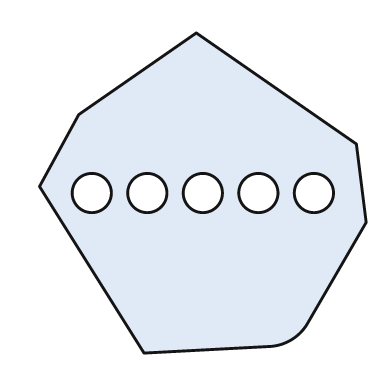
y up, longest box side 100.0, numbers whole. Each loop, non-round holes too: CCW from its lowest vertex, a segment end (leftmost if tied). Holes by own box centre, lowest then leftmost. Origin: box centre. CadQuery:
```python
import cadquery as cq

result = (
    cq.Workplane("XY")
    .moveTo(-18.0, -49.0)
    .lineTo(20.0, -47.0)
    .threePointArc((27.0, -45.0), (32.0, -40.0))
    .lineTo(50.0, -9.0)
    .lineTo(47.0, 15.0)
    .lineTo(-2.0, 49.0)
    .lineTo(-38.0, 24.0)
    .lineTo(-50.0, 2.0)
    .close()
    .moveTo(-34.0, 0.0)
    .circle(6.0)
    .moveTo(-17.0, 0.0)
    .circle(6.0)
    .moveTo(0.0, 0.0)
    .circle(6.0)
    .moveTo(17.0, 0.0)
    .circle(6.0)
    .moveTo(34.0, 0.0)
    .circle(6.0)
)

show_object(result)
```